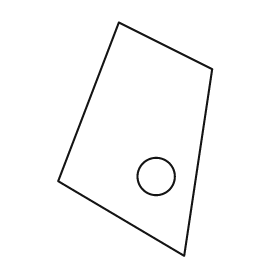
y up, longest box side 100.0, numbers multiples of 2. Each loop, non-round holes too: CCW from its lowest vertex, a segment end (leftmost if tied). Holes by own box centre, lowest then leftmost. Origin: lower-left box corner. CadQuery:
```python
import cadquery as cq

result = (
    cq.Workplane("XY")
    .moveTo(54.0, 0.0)
    .lineTo(66.0, 80.0)
    .lineTo(26.0, 100.0)
    .lineTo(0.0, 32.0)
    .close()
    .moveTo(42.0, 34.0)
    .circle(8.0)
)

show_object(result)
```